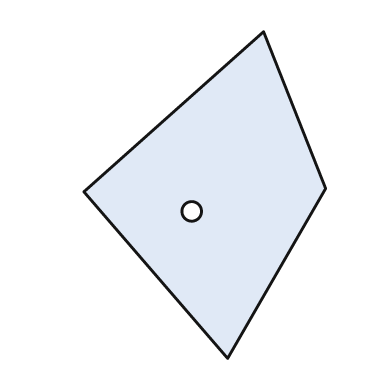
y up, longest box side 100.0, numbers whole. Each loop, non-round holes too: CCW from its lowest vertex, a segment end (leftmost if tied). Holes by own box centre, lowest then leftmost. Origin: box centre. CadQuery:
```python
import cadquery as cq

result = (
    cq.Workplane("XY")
    .moveTo(7.0, -50.0)
    .lineTo(37.0, 2.0)
    .lineTo(18.0, 50.0)
    .lineTo(-37.0, 1.0)
    .close()
    .moveTo(-4.0, -5.0)
    .circle(3.0)
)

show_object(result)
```